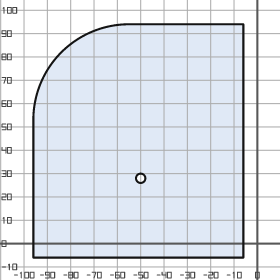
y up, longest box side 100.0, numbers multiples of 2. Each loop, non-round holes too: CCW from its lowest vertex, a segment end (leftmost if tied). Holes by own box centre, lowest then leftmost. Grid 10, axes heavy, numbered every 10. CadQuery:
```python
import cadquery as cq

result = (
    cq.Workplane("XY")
    .moveTo(-96.0, -6.0)
    .lineTo(-6.0, -6.0)
    .lineTo(-6.0, 94.0)
    .lineTo(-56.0, 94.0)
    .threePointArc((-84.0, 82.0), (-96.0, 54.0))
    .close()
    .moveTo(-50.0, 28.0)
    .circle(2.0)
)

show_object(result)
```